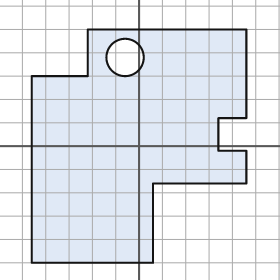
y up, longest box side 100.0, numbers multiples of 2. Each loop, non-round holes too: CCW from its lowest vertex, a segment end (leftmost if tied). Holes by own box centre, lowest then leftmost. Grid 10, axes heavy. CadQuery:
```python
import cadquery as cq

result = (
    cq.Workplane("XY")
    .moveTo(-46.0, -50.0)
    .lineTo(6.0, -50.0)
    .lineTo(6.0, -16.0)
    .lineTo(46.0, -16.0)
    .lineTo(46.0, -2.0)
    .lineTo(34.0, -2.0)
    .lineTo(34.0, 12.0)
    .lineTo(46.0, 12.0)
    .lineTo(46.0, 50.0)
    .lineTo(-22.0, 50.0)
    .lineTo(-22.0, 30.0)
    .lineTo(-46.0, 30.0)
    .close()
    .moveTo(-6.0, 38.0)
    .circle(8.0)
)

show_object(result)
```